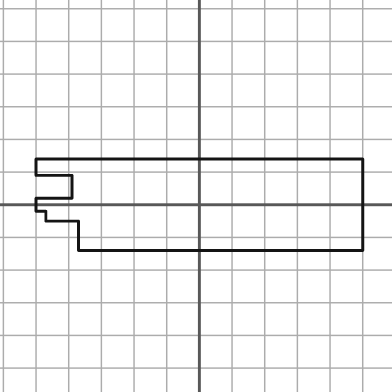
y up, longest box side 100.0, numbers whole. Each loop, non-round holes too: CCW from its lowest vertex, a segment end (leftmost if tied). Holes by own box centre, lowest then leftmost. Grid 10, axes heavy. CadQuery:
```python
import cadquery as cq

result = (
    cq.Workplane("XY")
    .moveTo(-37.0, -14.0)
    .lineTo(50.0, -14.0)
    .lineTo(50.0, 14.0)
    .lineTo(-50.0, 14.0)
    .lineTo(-50.0, 9.0)
    .lineTo(-39.0, 9.0)
    .lineTo(-39.0, 2.0)
    .lineTo(-50.0, 2.0)
    .lineTo(-50.0, -2.0)
    .lineTo(-47.0, -2.0)
    .lineTo(-47.0, -5.0)
    .lineTo(-37.0, -5.0)
    .close()
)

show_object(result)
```